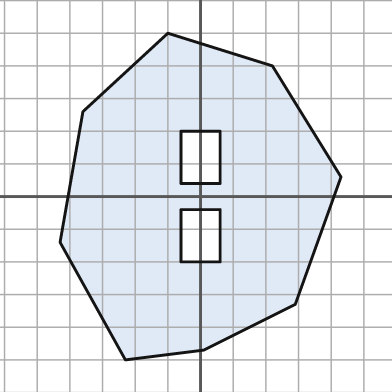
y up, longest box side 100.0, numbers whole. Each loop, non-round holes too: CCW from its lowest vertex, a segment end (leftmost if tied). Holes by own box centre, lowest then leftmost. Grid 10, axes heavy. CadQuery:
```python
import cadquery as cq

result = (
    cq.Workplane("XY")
    .moveTo(-23.0, -50.0)
    .lineTo(1.0, -47.0)
    .lineTo(29.0, -33.0)
    .lineTo(43.0, 6.0)
    .lineTo(22.0, 40.0)
    .lineTo(-10.0, 50.0)
    .lineTo(-36.0, 26.0)
    .lineTo(-43.0, -14.0)
    .close()
    .moveTo(-6.0, -20.0)
    .lineTo(6.0, -20.0)
    .lineTo(6.0, -4.0)
    .lineTo(-6.0, -4.0)
    .close()
    .moveTo(-6.0, 4.0)
    .lineTo(6.0, 4.0)
    .lineTo(6.0, 20.0)
    .lineTo(-6.0, 20.0)
    .close()
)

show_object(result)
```